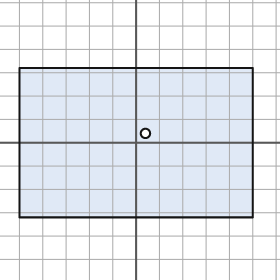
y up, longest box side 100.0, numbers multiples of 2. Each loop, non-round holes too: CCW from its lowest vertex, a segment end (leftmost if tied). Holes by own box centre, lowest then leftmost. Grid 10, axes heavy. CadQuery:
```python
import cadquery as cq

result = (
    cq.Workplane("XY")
    .moveTo(-50.0, -32.0)
    .lineTo(50.0, -32.0)
    .lineTo(50.0, 32.0)
    .lineTo(-50.0, 32.0)
    .close()
    .moveTo(4.0, 4.0)
    .circle(2.0)
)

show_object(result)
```